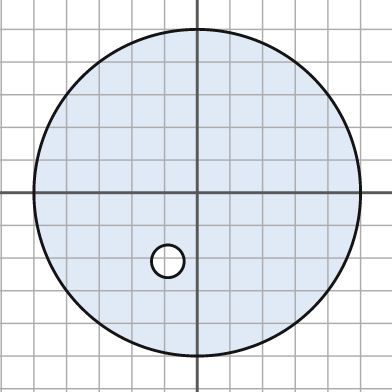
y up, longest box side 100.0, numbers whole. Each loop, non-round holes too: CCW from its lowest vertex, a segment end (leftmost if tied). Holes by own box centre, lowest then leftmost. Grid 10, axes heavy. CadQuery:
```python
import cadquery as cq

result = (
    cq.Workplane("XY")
    .moveTo(0.0, 0.0)
    .circle(50.0)
    .moveTo(-9.0, -21.0)
    .circle(5.0)
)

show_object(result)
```